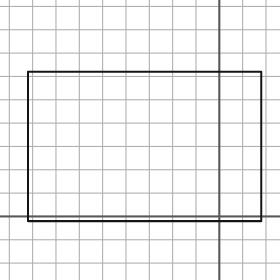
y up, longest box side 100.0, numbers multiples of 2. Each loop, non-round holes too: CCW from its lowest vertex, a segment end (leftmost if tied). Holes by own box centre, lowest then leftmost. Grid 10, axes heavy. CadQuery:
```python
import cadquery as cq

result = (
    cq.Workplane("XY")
    .moveTo(-82.0, -2.0)
    .lineTo(18.0, -2.0)
    .lineTo(18.0, 62.0)
    .lineTo(-82.0, 62.0)
    .close()
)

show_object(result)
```